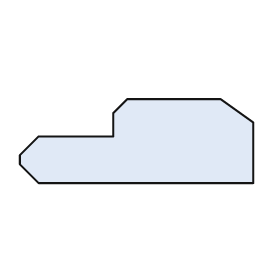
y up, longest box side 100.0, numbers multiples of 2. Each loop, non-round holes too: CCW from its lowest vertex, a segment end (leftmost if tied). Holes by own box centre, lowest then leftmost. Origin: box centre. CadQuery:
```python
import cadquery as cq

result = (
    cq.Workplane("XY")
    .moveTo(-42.0, -18.0)
    .lineTo(50.0, -18.0)
    .lineTo(50.0, 8.0)
    .lineTo(36.0, 18.0)
    .lineTo(-4.0, 18.0)
    .lineTo(-10.0, 12.0)
    .lineTo(-10.0, 2.0)
    .lineTo(-42.0, 2.0)
    .lineTo(-50.0, -6.0)
    .lineTo(-50.0, -10.0)
    .close()
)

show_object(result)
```